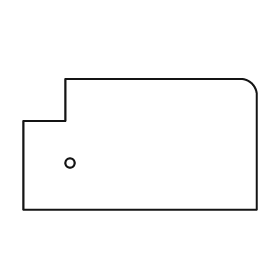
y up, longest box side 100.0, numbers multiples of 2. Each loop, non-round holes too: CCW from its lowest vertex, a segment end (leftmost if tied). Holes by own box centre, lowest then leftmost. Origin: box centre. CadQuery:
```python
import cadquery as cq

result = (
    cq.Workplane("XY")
    .moveTo(-50.0, -28.0)
    .lineTo(50.0, -28.0)
    .lineTo(50.0, 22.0)
    .threePointArc((48.0, 26.0), (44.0, 28.0))
    .lineTo(-32.0, 28.0)
    .lineTo(-32.0, 10.0)
    .lineTo(-50.0, 10.0)
    .close()
    .moveTo(-30.0, -8.0)
    .circle(2.0)
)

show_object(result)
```